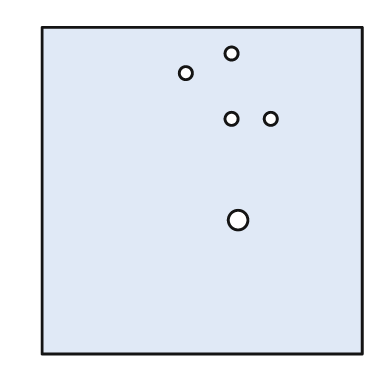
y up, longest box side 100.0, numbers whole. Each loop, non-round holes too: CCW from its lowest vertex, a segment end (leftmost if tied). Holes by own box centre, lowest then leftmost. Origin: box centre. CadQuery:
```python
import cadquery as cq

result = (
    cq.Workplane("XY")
    .moveTo(-49.0, -50.0)
    .lineTo(49.0, -50.0)
    .lineTo(49.0, 50.0)
    .lineTo(-49.0, 50.0)
    .close()
    .moveTo(11.0, -9.0)
    .circle(3.0)
    .moveTo(9.0, 22.0)
    .circle(2.0)
    .moveTo(21.0, 22.0)
    .circle(2.0)
    .moveTo(-5.0, 36.0)
    .circle(2.0)
    .moveTo(9.0, 42.0)
    .circle(2.0)
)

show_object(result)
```